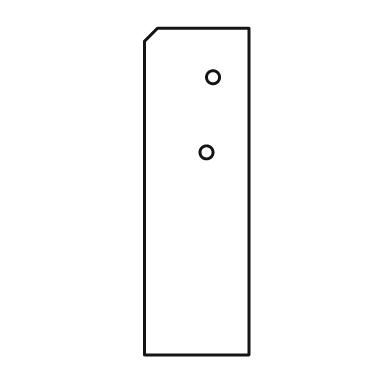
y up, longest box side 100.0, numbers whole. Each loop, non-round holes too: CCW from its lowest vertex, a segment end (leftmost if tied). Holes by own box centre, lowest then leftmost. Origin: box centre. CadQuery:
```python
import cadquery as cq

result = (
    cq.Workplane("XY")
    .moveTo(-16.0, -50.0)
    .lineTo(16.0, -50.0)
    .lineTo(16.0, 50.0)
    .lineTo(-12.0, 50.0)
    .lineTo(-16.0, 46.0)
    .close()
    .moveTo(3.0, 12.0)
    .circle(2.0)
    .moveTo(5.0, 35.0)
    .circle(2.0)
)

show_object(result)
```